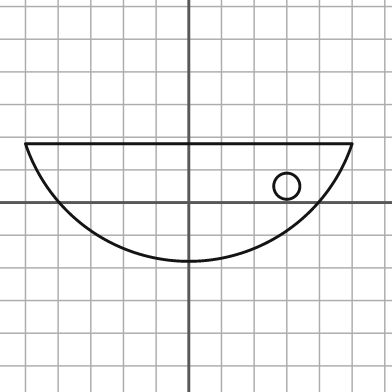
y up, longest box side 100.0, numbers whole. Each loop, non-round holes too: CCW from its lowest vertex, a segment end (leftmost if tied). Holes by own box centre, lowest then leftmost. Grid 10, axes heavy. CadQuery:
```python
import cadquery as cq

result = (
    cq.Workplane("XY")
    .moveTo(-50.0, 18.0)
    .threePointArc((0.0, -18.0), (50.0, 18.0))
    .close()
    .moveTo(30.0, 5.0)
    .circle(4.0)
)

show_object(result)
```